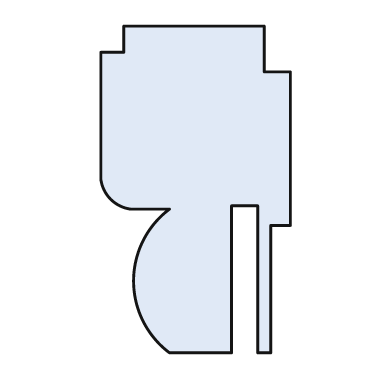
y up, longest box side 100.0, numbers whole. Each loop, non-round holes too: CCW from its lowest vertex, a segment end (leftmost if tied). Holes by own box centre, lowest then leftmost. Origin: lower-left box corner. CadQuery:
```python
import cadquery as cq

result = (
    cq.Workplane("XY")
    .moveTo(21.0, 0.0)
    .lineTo(40.0, 0.0)
    .lineTo(40.0, 45.0)
    .lineTo(48.0, 45.0)
    .lineTo(48.0, 0.0)
    .lineTo(52.0, 0.0)
    .lineTo(52.0, 39.0)
    .lineTo(58.0, 39.0)
    .lineTo(58.0, 86.0)
    .lineTo(50.0, 86.0)
    .lineTo(50.0, 100.0)
    .lineTo(7.0, 100.0)
    .lineTo(7.0, 92.0)
    .lineTo(0.0, 92.0)
    .lineTo(0.0, 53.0)
    .threePointArc((3.0, 47.0), (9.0, 44.0))
    .lineTo(21.0, 44.0)
    .threePointArc((10.0, 22.0), (21.0, 0.0))
    .close()
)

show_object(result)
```